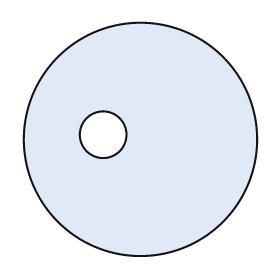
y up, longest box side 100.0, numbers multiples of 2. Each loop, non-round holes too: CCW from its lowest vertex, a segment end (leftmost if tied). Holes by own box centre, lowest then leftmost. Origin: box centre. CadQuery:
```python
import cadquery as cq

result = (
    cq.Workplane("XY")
    .moveTo(0.0, 0.0)
    .circle(50.0)
    .moveTo(-16.0, 2.0)
    .circle(10.0)
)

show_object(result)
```